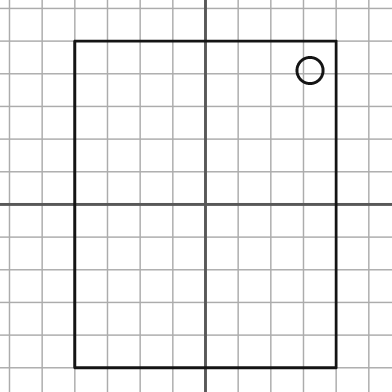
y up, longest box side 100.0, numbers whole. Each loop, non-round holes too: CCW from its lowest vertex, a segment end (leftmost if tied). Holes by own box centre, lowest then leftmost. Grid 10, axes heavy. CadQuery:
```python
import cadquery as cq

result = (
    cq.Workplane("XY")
    .moveTo(-40.0, -50.0)
    .lineTo(40.0, -50.0)
    .lineTo(40.0, 50.0)
    .lineTo(-40.0, 50.0)
    .close()
    .moveTo(32.0, 41.0)
    .circle(4.0)
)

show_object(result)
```